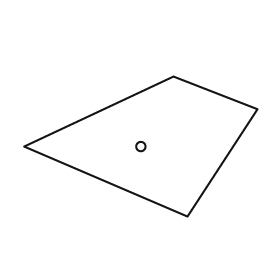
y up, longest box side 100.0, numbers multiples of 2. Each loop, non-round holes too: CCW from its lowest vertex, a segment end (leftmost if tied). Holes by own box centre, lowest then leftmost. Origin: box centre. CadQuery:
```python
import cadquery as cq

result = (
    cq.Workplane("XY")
    .moveTo(20.0, -30.0)
    .lineTo(50.0, 16.0)
    .lineTo(14.0, 30.0)
    .lineTo(-50.0, 0.0)
    .close()
    .moveTo(0.0, 0.0)
    .circle(2.0)
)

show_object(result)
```